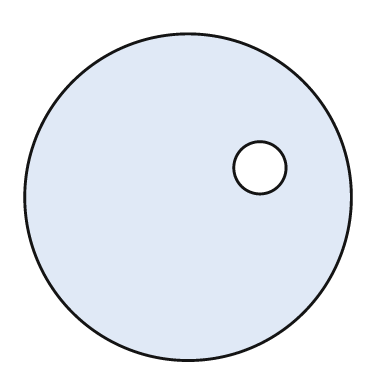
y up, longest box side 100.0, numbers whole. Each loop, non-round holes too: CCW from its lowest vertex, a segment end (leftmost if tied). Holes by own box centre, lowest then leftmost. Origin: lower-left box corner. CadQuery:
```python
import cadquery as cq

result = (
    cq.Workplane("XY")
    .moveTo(50.0, 50.0)
    .circle(50.0)
    .moveTo(72.0, 59.0)
    .circle(8.0)
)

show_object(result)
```